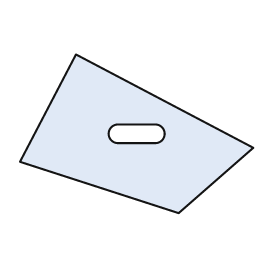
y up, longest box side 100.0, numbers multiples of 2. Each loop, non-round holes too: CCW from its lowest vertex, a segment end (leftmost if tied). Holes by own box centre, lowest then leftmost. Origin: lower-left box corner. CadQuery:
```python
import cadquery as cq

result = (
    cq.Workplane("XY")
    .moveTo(68.0, 0.0)
    .lineTo(100.0, 28.0)
    .lineTo(24.0, 68.0)
    .lineTo(0.0, 22.0)
    .close()
    .moveTo(42.0, 30.0)
    .lineTo(58.0, 30.0)
    .threePointArc((62.0, 34.0), (58.0, 38.0))
    .lineTo(42.0, 38.0)
    .threePointArc((38.0, 34.0), (42.0, 30.0))
    .close()
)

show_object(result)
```